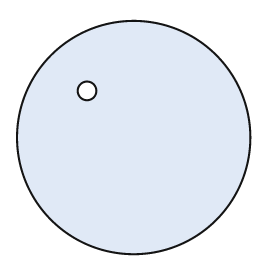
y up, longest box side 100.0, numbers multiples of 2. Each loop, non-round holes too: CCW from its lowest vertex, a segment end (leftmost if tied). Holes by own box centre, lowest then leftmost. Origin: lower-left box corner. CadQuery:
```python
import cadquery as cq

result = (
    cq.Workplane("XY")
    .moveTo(50.0, 50.0)
    .circle(50.0)
    .moveTo(30.0, 70.0)
    .circle(4.0)
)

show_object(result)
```